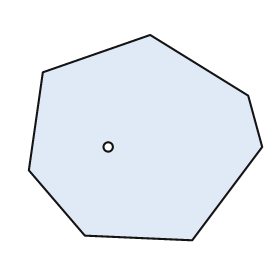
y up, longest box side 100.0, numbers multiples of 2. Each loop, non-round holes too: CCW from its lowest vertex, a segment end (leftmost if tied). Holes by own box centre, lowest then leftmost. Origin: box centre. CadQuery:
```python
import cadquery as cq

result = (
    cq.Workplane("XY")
    .moveTo(20.0, -44.0)
    .lineTo(50.0, -4.0)
    .lineTo(44.0, 18.0)
    .lineTo(2.0, 44.0)
    .lineTo(-44.0, 28.0)
    .lineTo(-50.0, -14.0)
    .lineTo(-26.0, -42.0)
    .close()
    .moveTo(-16.0, -4.0)
    .circle(2.0)
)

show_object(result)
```